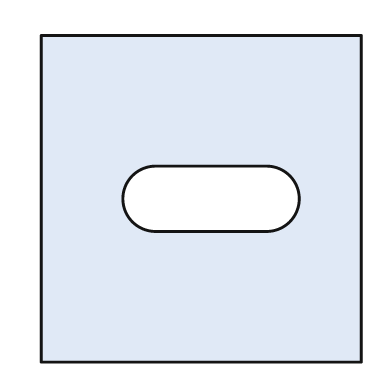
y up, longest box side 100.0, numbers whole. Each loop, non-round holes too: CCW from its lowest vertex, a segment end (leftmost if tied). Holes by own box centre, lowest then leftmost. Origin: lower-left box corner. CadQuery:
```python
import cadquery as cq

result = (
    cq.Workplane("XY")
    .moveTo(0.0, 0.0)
    .lineTo(98.0, 0.0)
    .lineTo(98.0, 100.0)
    .lineTo(0.0, 100.0)
    .close()
    .moveTo(35.0, 40.0)
    .lineTo(69.0, 40.0)
    .threePointArc((79.0, 50.0), (69.0, 60.0))
    .lineTo(35.0, 60.0)
    .threePointArc((25.0, 50.0), (35.0, 40.0))
    .close()
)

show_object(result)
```